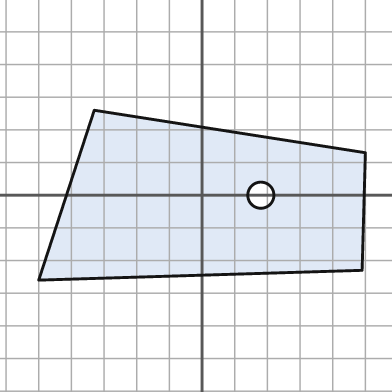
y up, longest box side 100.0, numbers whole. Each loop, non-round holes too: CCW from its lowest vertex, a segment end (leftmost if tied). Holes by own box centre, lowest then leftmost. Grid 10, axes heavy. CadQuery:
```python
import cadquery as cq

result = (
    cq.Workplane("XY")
    .moveTo(-50.0, -26.0)
    .lineTo(49.0, -23.0)
    .lineTo(50.0, 13.0)
    .lineTo(-33.0, 26.0)
    .close()
    .moveTo(18.0, 0.0)
    .circle(4.0)
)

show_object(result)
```